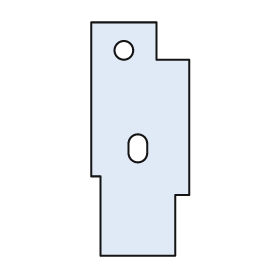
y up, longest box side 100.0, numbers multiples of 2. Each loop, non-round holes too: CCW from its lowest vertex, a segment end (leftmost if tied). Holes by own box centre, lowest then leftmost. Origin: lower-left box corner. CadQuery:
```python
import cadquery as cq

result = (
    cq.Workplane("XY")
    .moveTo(4.0, 0.0)
    .lineTo(36.0, 0.0)
    .lineTo(36.0, 26.0)
    .lineTo(42.0, 26.0)
    .lineTo(42.0, 84.0)
    .lineTo(28.0, 84.0)
    .lineTo(28.0, 100.0)
    .lineTo(0.0, 100.0)
    .lineTo(0.0, 34.0)
    .lineTo(4.0, 34.0)
    .close()
    .moveTo(16.0, 44.0)
    .threePointArc((20.0, 40.0), (24.0, 44.0))
    .lineTo(24.0, 48.0)
    .threePointArc((20.0, 52.0), (16.0, 48.0))
    .close()
    .moveTo(14.0, 88.0)
    .circle(4.0)
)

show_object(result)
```